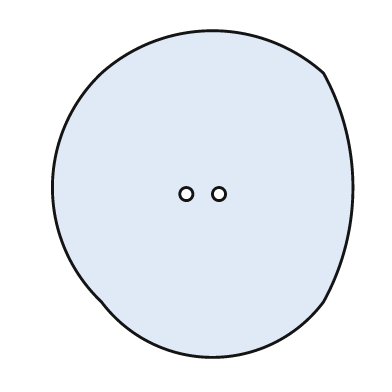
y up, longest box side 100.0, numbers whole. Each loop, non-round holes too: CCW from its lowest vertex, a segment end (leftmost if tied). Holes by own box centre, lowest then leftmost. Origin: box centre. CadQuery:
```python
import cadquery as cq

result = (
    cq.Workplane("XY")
    .moveTo(-31.0, -33.0)
    .threePointArc((3.0, -50.0), (37.0, -33.0))
    .threePointArc((46.0, 2.0), (37.0, 37.0))
    .threePointArc((3.0, 50.0), (-31.0, 37.0))
    .threePointArc((-46.0, 2.0), (-31.0, -33.0))
    .close()
    .moveTo(-5.0, 0.0)
    .circle(2.0)
    .moveTo(5.0, 0.0)
    .circle(2.0)
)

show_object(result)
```